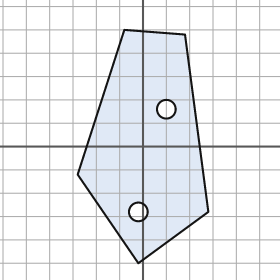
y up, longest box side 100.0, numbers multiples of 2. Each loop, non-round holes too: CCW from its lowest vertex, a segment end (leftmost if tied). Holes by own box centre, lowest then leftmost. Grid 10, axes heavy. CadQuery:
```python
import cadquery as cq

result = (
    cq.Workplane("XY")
    .moveTo(-2.0, -50.0)
    .lineTo(28.0, -28.0)
    .lineTo(18.0, 48.0)
    .lineTo(-8.0, 50.0)
    .lineTo(-28.0, -12.0)
    .close()
    .moveTo(-2.0, -28.0)
    .circle(4.0)
    .moveTo(10.0, 16.0)
    .circle(4.0)
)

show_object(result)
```